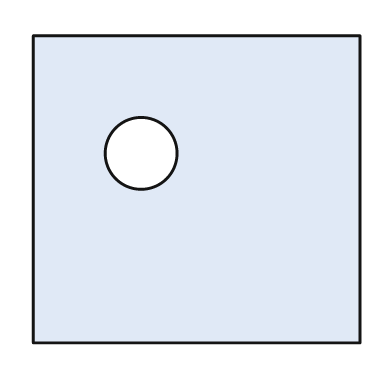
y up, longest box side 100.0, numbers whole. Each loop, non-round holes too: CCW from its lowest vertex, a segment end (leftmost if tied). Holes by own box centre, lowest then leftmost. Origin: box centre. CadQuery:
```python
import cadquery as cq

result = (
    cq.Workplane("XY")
    .moveTo(-50.0, -47.0)
    .lineTo(50.0, -47.0)
    .lineTo(50.0, 47.0)
    .lineTo(-50.0, 47.0)
    .close()
    .moveTo(-17.0, 11.0)
    .circle(11.0)
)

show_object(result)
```